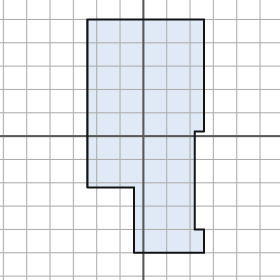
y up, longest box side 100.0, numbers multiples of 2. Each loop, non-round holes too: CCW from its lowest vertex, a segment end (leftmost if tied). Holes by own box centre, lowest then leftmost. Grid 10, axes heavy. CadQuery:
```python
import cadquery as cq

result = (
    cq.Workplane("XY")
    .moveTo(-4.0, -50.0)
    .lineTo(26.0, -50.0)
    .lineTo(26.0, -40.0)
    .lineTo(22.0, -40.0)
    .lineTo(22.0, 2.0)
    .lineTo(26.0, 2.0)
    .lineTo(26.0, 50.0)
    .lineTo(-24.0, 50.0)
    .lineTo(-24.0, -22.0)
    .lineTo(-4.0, -22.0)
    .close()
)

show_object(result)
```